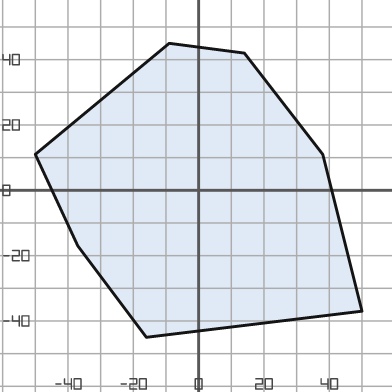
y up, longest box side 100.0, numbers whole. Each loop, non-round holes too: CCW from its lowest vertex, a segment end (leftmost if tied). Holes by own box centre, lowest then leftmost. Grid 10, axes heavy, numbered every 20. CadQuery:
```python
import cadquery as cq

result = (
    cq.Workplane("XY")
    .moveTo(-16.0, -45.0)
    .lineTo(50.0, -37.0)
    .lineTo(38.0, 11.0)
    .lineTo(14.0, 42.0)
    .lineTo(-9.0, 45.0)
    .lineTo(-50.0, 11.0)
    .lineTo(-37.0, -17.0)
    .close()
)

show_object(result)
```